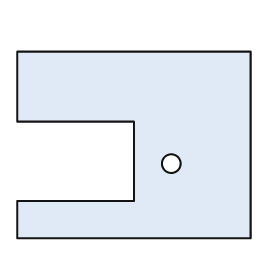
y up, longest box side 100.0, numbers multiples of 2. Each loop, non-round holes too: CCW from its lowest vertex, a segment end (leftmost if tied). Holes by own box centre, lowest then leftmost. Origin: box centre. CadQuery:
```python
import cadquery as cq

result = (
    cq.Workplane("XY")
    .moveTo(-50.0, -40.0)
    .lineTo(50.0, -40.0)
    .lineTo(50.0, 40.0)
    .lineTo(-50.0, 40.0)
    .lineTo(-50.0, 10.0)
    .lineTo(0.0, 10.0)
    .lineTo(0.0, -24.0)
    .lineTo(-50.0, -24.0)
    .close()
    .moveTo(16.0, -8.0)
    .circle(4.0)
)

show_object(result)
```